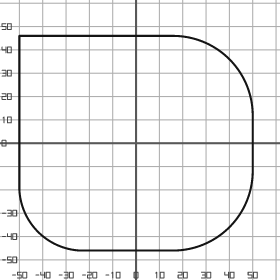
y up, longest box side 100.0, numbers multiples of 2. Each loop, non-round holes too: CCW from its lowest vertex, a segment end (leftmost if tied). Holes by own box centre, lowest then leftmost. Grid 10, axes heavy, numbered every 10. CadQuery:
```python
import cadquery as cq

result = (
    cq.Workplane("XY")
    .moveTo(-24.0, -46.0)
    .lineTo(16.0, -46.0)
    .threePointArc((40.0, -36.0), (50.0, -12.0))
    .lineTo(50.0, 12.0)
    .threePointArc((40.0, 36.0), (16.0, 46.0))
    .lineTo(-50.0, 46.0)
    .lineTo(-50.0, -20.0)
    .threePointArc((-42.0, -38.0), (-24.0, -46.0))
    .close()
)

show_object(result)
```